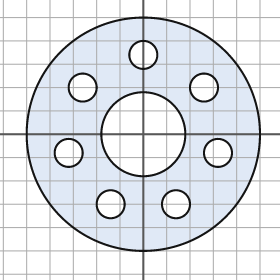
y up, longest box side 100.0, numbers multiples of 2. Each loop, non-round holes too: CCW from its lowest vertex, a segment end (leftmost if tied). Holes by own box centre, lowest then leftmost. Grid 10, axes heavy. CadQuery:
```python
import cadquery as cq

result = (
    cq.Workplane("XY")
    .moveTo(0.0, 0.0)
    .circle(50.0)
    .moveTo(-14.0, -30.0)
    .circle(6.0)
    .moveTo(14.0, -30.0)
    .circle(6.0)
    .moveTo(-32.0, -8.0)
    .circle(6.0)
    .moveTo(32.0, -8.0)
    .circle(6.0)
    .moveTo(0.0, 0.0)
    .circle(18.0)
    .moveTo(-26.0, 20.0)
    .circle(6.0)
    .moveTo(26.0, 20.0)
    .circle(6.0)
    .moveTo(0.0, 34.0)
    .circle(6.0)
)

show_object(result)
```